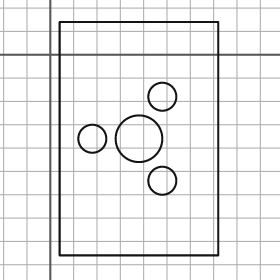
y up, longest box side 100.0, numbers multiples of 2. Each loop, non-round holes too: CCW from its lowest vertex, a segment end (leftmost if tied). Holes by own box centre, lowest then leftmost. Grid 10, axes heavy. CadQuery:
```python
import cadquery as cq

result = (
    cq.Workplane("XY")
    .moveTo(4.0, -86.0)
    .lineTo(72.0, -86.0)
    .lineTo(72.0, 14.0)
    .lineTo(4.0, 14.0)
    .close()
    .moveTo(48.0, -54.0)
    .circle(6.0)
    .moveTo(18.0, -36.0)
    .circle(6.0)
    .moveTo(38.0, -36.0)
    .circle(10.0)
    .moveTo(48.0, -18.0)
    .circle(6.0)
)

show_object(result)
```